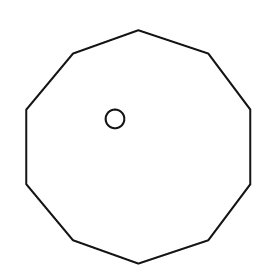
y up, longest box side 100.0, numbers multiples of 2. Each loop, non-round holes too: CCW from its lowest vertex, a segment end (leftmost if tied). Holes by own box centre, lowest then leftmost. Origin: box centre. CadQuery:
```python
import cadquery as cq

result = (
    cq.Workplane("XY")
    .moveTo(0.0, -50.0)
    .lineTo(30.0, -40.0)
    .lineTo(48.0, -16.0)
    .lineTo(48.0, 16.0)
    .lineTo(30.0, 40.0)
    .lineTo(0.0, 50.0)
    .lineTo(-28.0, 40.0)
    .lineTo(-48.0, 16.0)
    .lineTo(-48.0, -16.0)
    .lineTo(-28.0, -40.0)
    .close()
    .moveTo(-10.0, 12.0)
    .circle(4.0)
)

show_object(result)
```